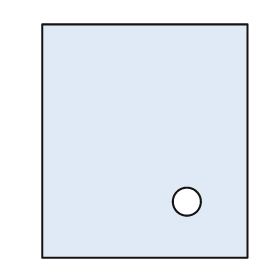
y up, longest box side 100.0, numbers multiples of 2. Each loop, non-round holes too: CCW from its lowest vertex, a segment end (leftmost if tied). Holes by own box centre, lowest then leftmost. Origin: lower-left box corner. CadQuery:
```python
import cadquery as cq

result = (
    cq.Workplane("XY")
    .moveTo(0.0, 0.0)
    .lineTo(88.0, 0.0)
    .lineTo(88.0, 100.0)
    .lineTo(0.0, 100.0)
    .close()
    .moveTo(62.0, 24.0)
    .circle(6.0)
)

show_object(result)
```